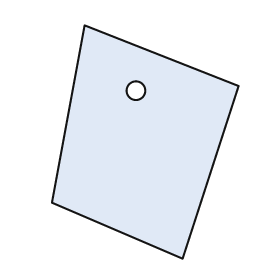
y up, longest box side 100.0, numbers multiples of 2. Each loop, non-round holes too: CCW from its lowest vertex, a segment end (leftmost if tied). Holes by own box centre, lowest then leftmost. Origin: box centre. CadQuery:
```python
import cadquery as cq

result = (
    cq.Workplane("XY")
    .moveTo(16.0, -50.0)
    .lineTo(40.0, 24.0)
    .lineTo(-26.0, 50.0)
    .lineTo(-40.0, -26.0)
    .close()
    .moveTo(-4.0, 22.0)
    .circle(4.0)
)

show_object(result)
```